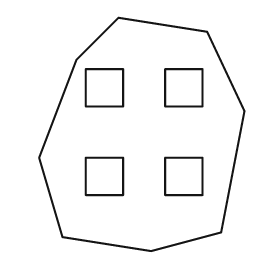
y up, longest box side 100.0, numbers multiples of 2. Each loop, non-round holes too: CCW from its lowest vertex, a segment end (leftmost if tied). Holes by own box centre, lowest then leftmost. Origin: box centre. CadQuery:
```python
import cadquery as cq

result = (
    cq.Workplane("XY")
    .moveTo(4.0, -50.0)
    .lineTo(34.0, -42.0)
    .lineTo(44.0, 10.0)
    .lineTo(28.0, 44.0)
    .lineTo(-10.0, 50.0)
    .lineTo(-28.0, 32.0)
    .lineTo(-44.0, -10.0)
    .lineTo(-34.0, -44.0)
    .close()
    .moveTo(-24.0, -26.0)
    .lineTo(-8.0, -26.0)
    .lineTo(-8.0, -10.0)
    .lineTo(-24.0, -10.0)
    .close()
    .moveTo(10.0, -26.0)
    .lineTo(26.0, -26.0)
    .lineTo(26.0, -10.0)
    .lineTo(10.0, -10.0)
    .close()
    .moveTo(-24.0, 12.0)
    .lineTo(-8.0, 12.0)
    .lineTo(-8.0, 28.0)
    .lineTo(-24.0, 28.0)
    .close()
    .moveTo(10.0, 12.0)
    .lineTo(26.0, 12.0)
    .lineTo(26.0, 28.0)
    .lineTo(10.0, 28.0)
    .close()
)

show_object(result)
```